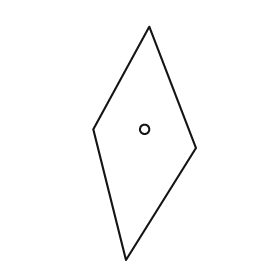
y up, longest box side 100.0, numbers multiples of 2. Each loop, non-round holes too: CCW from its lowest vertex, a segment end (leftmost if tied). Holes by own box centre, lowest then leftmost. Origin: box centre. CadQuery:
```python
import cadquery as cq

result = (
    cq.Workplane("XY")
    .moveTo(-8.0, -50.0)
    .lineTo(22.0, -2.0)
    .lineTo(2.0, 50.0)
    .lineTo(-22.0, 6.0)
    .close()
    .moveTo(0.0, 6.0)
    .circle(2.0)
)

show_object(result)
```